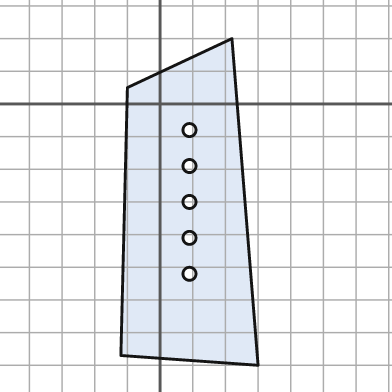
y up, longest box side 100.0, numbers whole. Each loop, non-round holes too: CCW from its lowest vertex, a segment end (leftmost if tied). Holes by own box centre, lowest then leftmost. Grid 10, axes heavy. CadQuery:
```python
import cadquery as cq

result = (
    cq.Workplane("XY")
    .moveTo(30.0, -80.0)
    .lineTo(22.0, 20.0)
    .lineTo(-10.0, 5.0)
    .lineTo(-12.0, -77.0)
    .close()
    .moveTo(9.0, -52.0)
    .circle(2.0)
    .moveTo(9.0, -41.0)
    .circle(2.0)
    .moveTo(9.0, -30.0)
    .circle(2.0)
    .moveTo(9.0, -19.0)
    .circle(2.0)
    .moveTo(9.0, -8.0)
    .circle(2.0)
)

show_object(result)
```